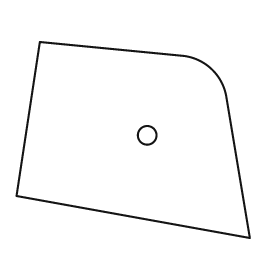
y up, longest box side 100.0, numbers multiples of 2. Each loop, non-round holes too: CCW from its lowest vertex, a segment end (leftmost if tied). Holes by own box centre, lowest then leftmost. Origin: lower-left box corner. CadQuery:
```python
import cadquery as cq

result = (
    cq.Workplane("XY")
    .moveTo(100.0, 0.0)
    .lineTo(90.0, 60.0)
    .threePointArc((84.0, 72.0), (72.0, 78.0))
    .lineTo(10.0, 84.0)
    .lineTo(0.0, 18.0)
    .close()
    .moveTo(56.0, 44.0)
    .circle(4.0)
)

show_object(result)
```